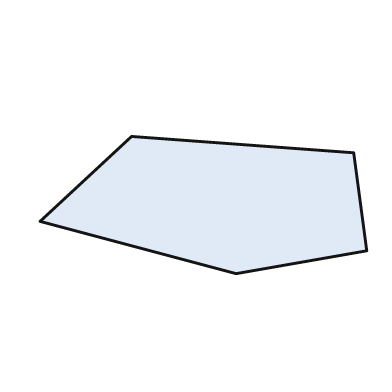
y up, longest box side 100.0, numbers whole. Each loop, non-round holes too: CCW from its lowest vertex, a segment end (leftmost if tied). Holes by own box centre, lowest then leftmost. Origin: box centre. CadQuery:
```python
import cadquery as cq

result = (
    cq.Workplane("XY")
    .moveTo(10.0, -21.0)
    .lineTo(50.0, -14.0)
    .lineTo(46.0, 16.0)
    .lineTo(-22.0, 21.0)
    .lineTo(-50.0, -5.0)
    .close()
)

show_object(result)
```